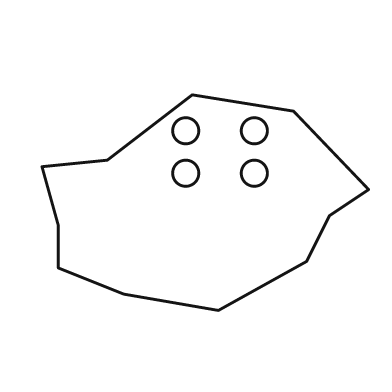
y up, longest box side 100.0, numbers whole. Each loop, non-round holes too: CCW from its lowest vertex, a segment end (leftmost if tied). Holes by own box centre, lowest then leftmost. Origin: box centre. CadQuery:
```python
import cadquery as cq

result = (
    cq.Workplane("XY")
    .moveTo(4.0, -33.0)
    .lineTo(31.0, -18.0)
    .lineTo(38.0, -4.0)
    .lineTo(50.0, 4.0)
    .lineTo(27.0, 28.0)
    .lineTo(-4.0, 33.0)
    .lineTo(-30.0, 13.0)
    .lineTo(-50.0, 11.0)
    .lineTo(-45.0, -7.0)
    .lineTo(-45.0, -20.0)
    .lineTo(-25.0, -28.0)
    .close()
    .moveTo(-6.0, 9.0)
    .circle(4.0)
    .moveTo(15.0, 9.0)
    .circle(4.0)
    .moveTo(-6.0, 22.0)
    .circle(4.0)
    .moveTo(15.0, 22.0)
    .circle(4.0)
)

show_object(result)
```